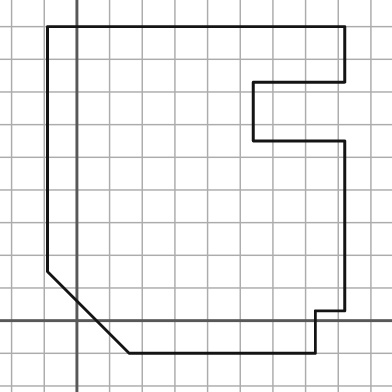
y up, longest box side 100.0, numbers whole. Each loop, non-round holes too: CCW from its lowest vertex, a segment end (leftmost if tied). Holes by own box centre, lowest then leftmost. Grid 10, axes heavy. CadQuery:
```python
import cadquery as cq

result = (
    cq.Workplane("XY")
    .moveTo(16.0, -10.0)
    .lineTo(73.0, -10.0)
    .lineTo(73.0, 3.0)
    .lineTo(82.0, 3.0)
    .lineTo(82.0, 55.0)
    .lineTo(54.0, 55.0)
    .lineTo(54.0, 73.0)
    .lineTo(82.0, 73.0)
    .lineTo(82.0, 90.0)
    .lineTo(-9.0, 90.0)
    .lineTo(-9.0, 15.0)
    .close()
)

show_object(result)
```